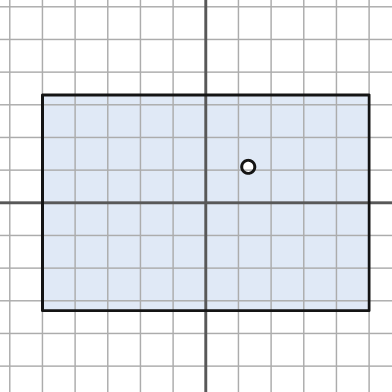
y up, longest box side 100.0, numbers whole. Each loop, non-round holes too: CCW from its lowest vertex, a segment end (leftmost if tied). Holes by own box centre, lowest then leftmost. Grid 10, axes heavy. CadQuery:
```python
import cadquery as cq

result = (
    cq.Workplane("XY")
    .moveTo(-50.0, -33.0)
    .lineTo(50.0, -33.0)
    .lineTo(50.0, 33.0)
    .lineTo(-50.0, 33.0)
    .close()
    .moveTo(13.0, 11.0)
    .circle(2.0)
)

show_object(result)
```